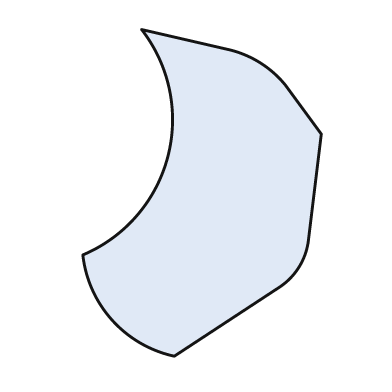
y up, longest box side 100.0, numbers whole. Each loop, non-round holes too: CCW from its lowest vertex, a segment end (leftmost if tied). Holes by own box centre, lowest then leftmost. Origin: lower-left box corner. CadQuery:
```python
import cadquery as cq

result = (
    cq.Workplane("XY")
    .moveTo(28.0, 0.0)
    .lineTo(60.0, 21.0)
    .threePointArc((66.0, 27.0), (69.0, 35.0))
    .lineTo(73.0, 68.0)
    .lineTo(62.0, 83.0)
    .threePointArc((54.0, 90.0), (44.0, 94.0))
    .lineTo(18.0, 100.0)
    .threePointArc((26.0, 61.0), (0.0, 31.0))
    .threePointArc((9.0, 11.0), (28.0, 0.0))
    .close()
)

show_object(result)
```